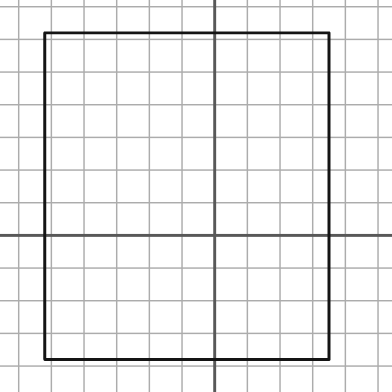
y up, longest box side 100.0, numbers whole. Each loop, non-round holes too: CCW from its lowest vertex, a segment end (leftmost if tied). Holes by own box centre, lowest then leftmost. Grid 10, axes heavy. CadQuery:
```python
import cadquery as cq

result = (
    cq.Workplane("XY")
    .moveTo(-52.0, -38.0)
    .lineTo(35.0, -38.0)
    .lineTo(35.0, 62.0)
    .lineTo(-52.0, 62.0)
    .close()
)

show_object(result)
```